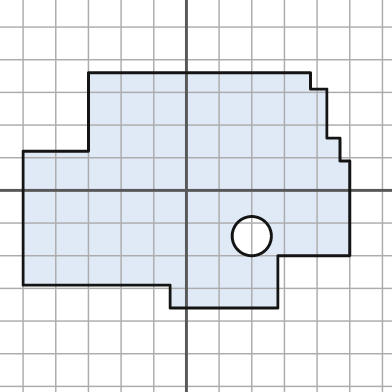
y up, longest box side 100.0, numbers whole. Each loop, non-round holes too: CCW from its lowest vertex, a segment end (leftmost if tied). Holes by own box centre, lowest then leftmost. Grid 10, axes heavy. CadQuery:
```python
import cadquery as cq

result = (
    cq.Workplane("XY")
    .moveTo(-5.0, -36.0)
    .lineTo(28.0, -36.0)
    .lineTo(28.0, -20.0)
    .lineTo(50.0, -20.0)
    .lineTo(50.0, 9.0)
    .lineTo(47.0, 9.0)
    .lineTo(47.0, 16.0)
    .lineTo(43.0, 16.0)
    .lineTo(43.0, 31.0)
    .lineTo(38.0, 31.0)
    .lineTo(38.0, 36.0)
    .lineTo(-30.0, 36.0)
    .lineTo(-30.0, 12.0)
    .lineTo(-50.0, 12.0)
    .lineTo(-50.0, -29.0)
    .lineTo(-5.0, -29.0)
    .close()
    .moveTo(20.0, -14.0)
    .circle(6.0)
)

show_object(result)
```